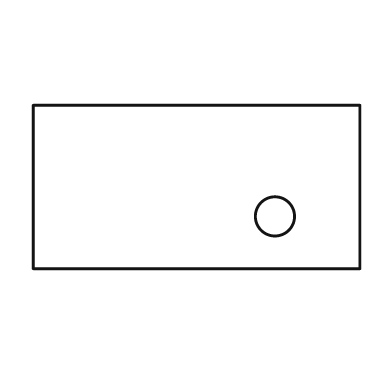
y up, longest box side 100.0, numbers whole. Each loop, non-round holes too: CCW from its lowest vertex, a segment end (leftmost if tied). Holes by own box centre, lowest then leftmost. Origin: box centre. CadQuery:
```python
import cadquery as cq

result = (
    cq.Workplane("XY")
    .moveTo(-50.0, -25.0)
    .lineTo(50.0, -25.0)
    .lineTo(50.0, 25.0)
    .lineTo(-50.0, 25.0)
    .close()
    .moveTo(24.0, -9.0)
    .circle(6.0)
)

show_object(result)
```